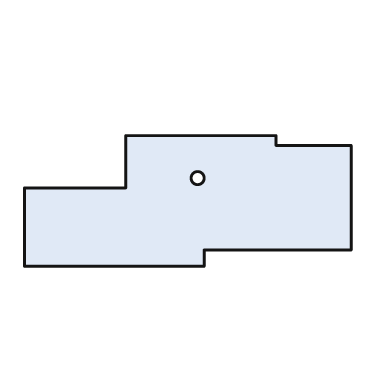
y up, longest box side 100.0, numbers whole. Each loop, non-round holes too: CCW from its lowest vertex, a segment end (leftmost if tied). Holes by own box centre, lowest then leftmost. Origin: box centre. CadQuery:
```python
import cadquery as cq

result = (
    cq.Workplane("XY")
    .moveTo(-50.0, -20.0)
    .lineTo(5.0, -20.0)
    .lineTo(5.0, -15.0)
    .lineTo(50.0, -15.0)
    .lineTo(50.0, 17.0)
    .lineTo(27.0, 17.0)
    .lineTo(27.0, 20.0)
    .lineTo(-19.0, 20.0)
    .lineTo(-19.0, 4.0)
    .lineTo(-50.0, 4.0)
    .close()
    .moveTo(3.0, 7.0)
    .circle(2.0)
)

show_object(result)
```